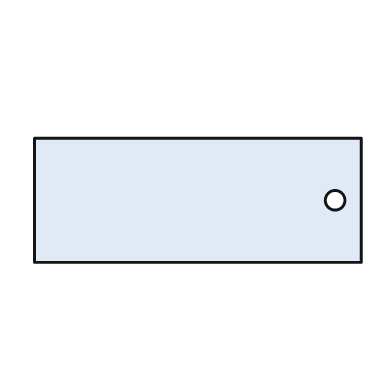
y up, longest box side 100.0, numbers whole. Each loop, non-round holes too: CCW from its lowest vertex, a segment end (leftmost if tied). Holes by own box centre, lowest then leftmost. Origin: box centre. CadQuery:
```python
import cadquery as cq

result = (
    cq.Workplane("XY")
    .moveTo(-50.0, -19.0)
    .lineTo(50.0, -19.0)
    .lineTo(50.0, 19.0)
    .lineTo(-50.0, 19.0)
    .close()
    .moveTo(42.0, 0.0)
    .circle(3.0)
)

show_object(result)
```